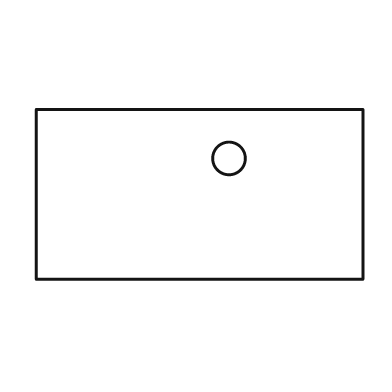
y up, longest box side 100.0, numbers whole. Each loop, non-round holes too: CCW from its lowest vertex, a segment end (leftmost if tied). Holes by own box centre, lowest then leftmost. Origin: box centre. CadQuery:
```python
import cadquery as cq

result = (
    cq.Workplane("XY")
    .moveTo(-50.0, -26.0)
    .lineTo(50.0, -26.0)
    .lineTo(50.0, 26.0)
    .lineTo(-50.0, 26.0)
    .close()
    .moveTo(9.0, 11.0)
    .circle(5.0)
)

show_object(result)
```